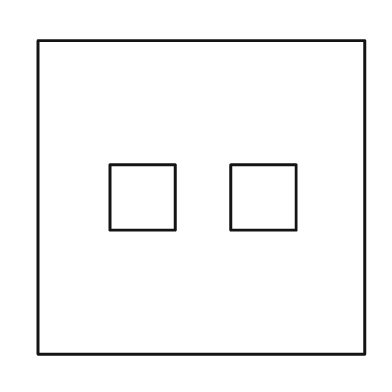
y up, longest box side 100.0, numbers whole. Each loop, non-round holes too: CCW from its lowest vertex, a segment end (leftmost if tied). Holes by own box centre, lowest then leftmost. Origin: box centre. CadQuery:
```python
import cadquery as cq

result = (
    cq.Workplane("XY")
    .moveTo(-50.0, -48.0)
    .lineTo(50.0, -48.0)
    .lineTo(50.0, 48.0)
    .lineTo(-50.0, 48.0)
    .close()
    .moveTo(-28.0, -10.0)
    .lineTo(-8.0, -10.0)
    .lineTo(-8.0, 10.0)
    .lineTo(-28.0, 10.0)
    .close()
    .moveTo(9.0, -10.0)
    .lineTo(29.0, -10.0)
    .lineTo(29.0, 10.0)
    .lineTo(9.0, 10.0)
    .close()
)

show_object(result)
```